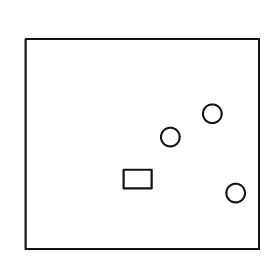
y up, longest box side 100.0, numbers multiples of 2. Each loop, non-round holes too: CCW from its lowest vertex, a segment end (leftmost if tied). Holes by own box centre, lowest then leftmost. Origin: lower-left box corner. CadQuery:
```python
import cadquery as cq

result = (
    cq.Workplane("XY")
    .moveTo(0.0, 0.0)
    .lineTo(100.0, 0.0)
    .lineTo(100.0, 90.0)
    .lineTo(0.0, 90.0)
    .close()
    .moveTo(90.0, 24.0)
    .circle(4.0)
    .moveTo(42.0, 26.0)
    .lineTo(54.0, 26.0)
    .lineTo(54.0, 34.0)
    .lineTo(42.0, 34.0)
    .close()
    .moveTo(62.0, 48.0)
    .circle(4.0)
    .moveTo(80.0, 58.0)
    .circle(4.0)
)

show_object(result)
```